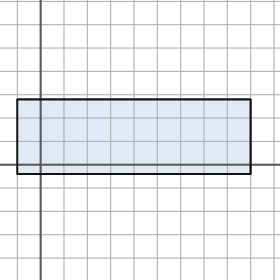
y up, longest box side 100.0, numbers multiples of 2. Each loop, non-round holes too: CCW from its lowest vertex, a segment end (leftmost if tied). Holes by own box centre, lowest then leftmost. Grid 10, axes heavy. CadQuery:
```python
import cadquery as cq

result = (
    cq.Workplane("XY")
    .moveTo(-10.0, -4.0)
    .lineTo(90.0, -4.0)
    .lineTo(90.0, 28.0)
    .lineTo(-10.0, 28.0)
    .close()
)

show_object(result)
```